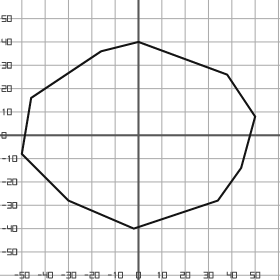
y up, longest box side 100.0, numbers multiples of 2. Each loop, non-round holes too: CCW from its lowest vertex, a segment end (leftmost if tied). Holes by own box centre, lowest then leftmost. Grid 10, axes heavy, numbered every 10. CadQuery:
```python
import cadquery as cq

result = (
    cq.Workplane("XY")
    .moveTo(-2.0, -40.0)
    .lineTo(34.0, -28.0)
    .lineTo(44.0, -14.0)
    .lineTo(50.0, 8.0)
    .lineTo(38.0, 26.0)
    .lineTo(0.0, 40.0)
    .lineTo(-16.0, 36.0)
    .lineTo(-46.0, 16.0)
    .lineTo(-50.0, -8.0)
    .lineTo(-30.0, -28.0)
    .close()
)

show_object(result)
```